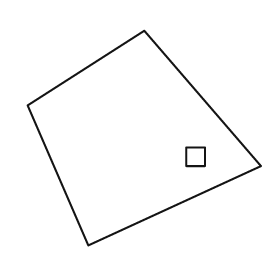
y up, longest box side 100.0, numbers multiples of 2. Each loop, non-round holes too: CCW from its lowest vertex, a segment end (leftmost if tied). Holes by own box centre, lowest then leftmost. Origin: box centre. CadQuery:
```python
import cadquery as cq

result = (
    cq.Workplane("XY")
    .moveTo(-24.0, -46.0)
    .lineTo(50.0, -12.0)
    .lineTo(0.0, 46.0)
    .lineTo(-50.0, 14.0)
    .close()
    .moveTo(18.0, -12.0)
    .lineTo(26.0, -12.0)
    .lineTo(26.0, -4.0)
    .lineTo(18.0, -4.0)
    .close()
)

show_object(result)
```